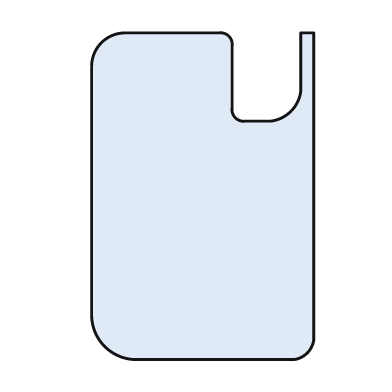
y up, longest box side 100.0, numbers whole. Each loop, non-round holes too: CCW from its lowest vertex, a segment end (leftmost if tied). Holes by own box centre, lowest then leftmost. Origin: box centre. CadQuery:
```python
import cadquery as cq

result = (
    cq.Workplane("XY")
    .moveTo(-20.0, -50.0)
    .lineTo(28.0, -50.0)
    .threePointArc((32.0, -48.0), (34.0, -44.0))
    .lineTo(34.0, 50.0)
    .lineTo(30.0, 50.0)
    .lineTo(30.0, 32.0)
    .threePointArc((27.0, 26.0), (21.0, 23.0))
    .lineTo(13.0, 23.0)
    .threePointArc((10.0, 24.0), (9.0, 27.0))
    .lineTo(9.0, 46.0)
    .threePointArc((8.0, 49.0), (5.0, 50.0))
    .lineTo(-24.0, 50.0)
    .threePointArc((-31.0, 47.0), (-34.0, 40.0))
    .lineTo(-34.0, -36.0)
    .threePointArc((-30.0, -46.0), (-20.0, -50.0))
    .close()
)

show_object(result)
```